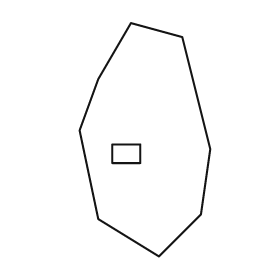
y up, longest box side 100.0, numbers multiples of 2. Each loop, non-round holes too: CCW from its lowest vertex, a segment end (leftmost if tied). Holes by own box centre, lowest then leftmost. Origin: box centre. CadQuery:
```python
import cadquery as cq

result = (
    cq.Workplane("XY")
    .moveTo(6.0, -50.0)
    .lineTo(24.0, -32.0)
    .lineTo(28.0, -4.0)
    .lineTo(16.0, 44.0)
    .lineTo(-6.0, 50.0)
    .lineTo(-20.0, 26.0)
    .lineTo(-28.0, 4.0)
    .lineTo(-20.0, -34.0)
    .close()
    .moveTo(-14.0, -10.0)
    .lineTo(-2.0, -10.0)
    .lineTo(-2.0, -2.0)
    .lineTo(-14.0, -2.0)
    .close()
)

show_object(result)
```